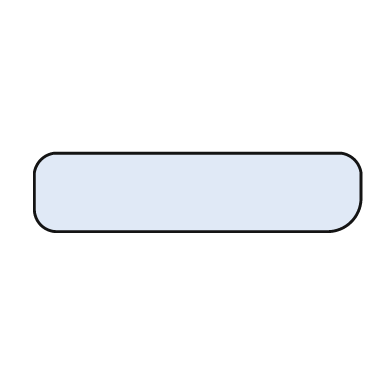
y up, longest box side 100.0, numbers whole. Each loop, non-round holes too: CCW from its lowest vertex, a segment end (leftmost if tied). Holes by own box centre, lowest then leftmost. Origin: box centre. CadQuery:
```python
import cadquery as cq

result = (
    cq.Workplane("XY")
    .moveTo(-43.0, -12.0)
    .lineTo(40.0, -12.0)
    .threePointArc((47.0, -9.0), (50.0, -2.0))
    .lineTo(50.0, 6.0)
    .threePointArc((48.0, 10.0), (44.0, 12.0))
    .lineTo(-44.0, 12.0)
    .threePointArc((-48.0, 10.0), (-50.0, 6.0))
    .lineTo(-50.0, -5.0)
    .threePointArc((-48.0, -10.0), (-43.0, -12.0))
    .close()
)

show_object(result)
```